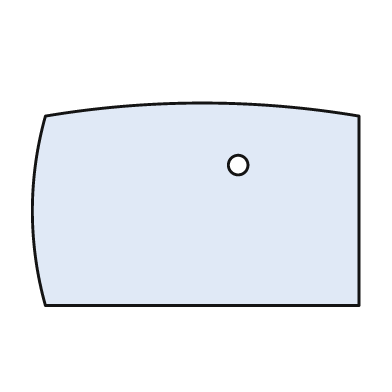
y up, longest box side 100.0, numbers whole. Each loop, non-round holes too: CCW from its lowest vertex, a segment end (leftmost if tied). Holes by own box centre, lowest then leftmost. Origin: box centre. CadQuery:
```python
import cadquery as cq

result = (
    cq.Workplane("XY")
    .moveTo(-46.0, -31.0)
    .lineTo(50.0, -31.0)
    .lineTo(50.0, 27.0)
    .threePointArc((2.0, 31.0), (-46.0, 27.0))
    .threePointArc((-50.0, -2.0), (-46.0, -31.0))
    .close()
    .moveTo(13.0, 12.0)
    .circle(3.0)
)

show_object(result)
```